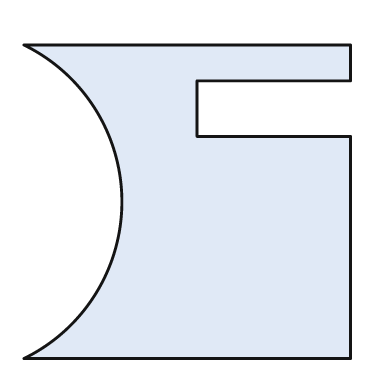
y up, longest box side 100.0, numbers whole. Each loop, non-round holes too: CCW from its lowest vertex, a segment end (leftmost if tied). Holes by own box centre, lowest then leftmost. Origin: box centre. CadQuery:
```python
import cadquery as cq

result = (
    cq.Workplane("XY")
    .moveTo(-50.0, -48.0)
    .lineTo(50.0, -48.0)
    .lineTo(50.0, 20.0)
    .lineTo(3.0, 20.0)
    .lineTo(3.0, 37.0)
    .lineTo(50.0, 37.0)
    .lineTo(50.0, 48.0)
    .lineTo(-50.0, 48.0)
    .threePointArc((-20.0, 0.0), (-50.0, -48.0))
    .close()
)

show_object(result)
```